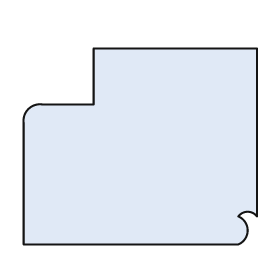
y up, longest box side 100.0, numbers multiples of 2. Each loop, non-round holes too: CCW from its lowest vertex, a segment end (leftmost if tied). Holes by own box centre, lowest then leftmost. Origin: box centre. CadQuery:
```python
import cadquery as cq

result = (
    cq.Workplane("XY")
    .moveTo(-50.0, -42.0)
    .lineTo(42.0, -42.0)
    .threePointArc((46.0, -36.0), (42.0, -30.0))
    .threePointArc((46.0, -28.0), (50.0, -30.0))
    .lineTo(50.0, 42.0)
    .lineTo(-20.0, 42.0)
    .lineTo(-20.0, 18.0)
    .lineTo(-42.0, 18.0)
    .threePointArc((-48.0, 16.0), (-50.0, 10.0))
    .close()
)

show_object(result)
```